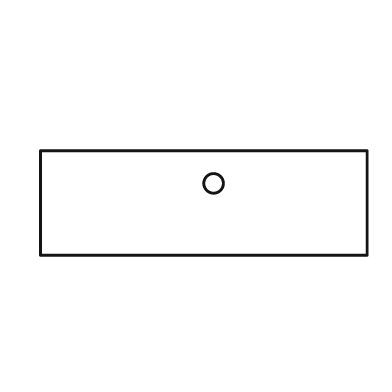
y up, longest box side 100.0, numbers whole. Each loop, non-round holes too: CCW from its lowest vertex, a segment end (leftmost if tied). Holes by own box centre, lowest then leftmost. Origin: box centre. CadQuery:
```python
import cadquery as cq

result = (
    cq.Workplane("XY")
    .moveTo(-50.0, -16.0)
    .lineTo(50.0, -16.0)
    .lineTo(50.0, 16.0)
    .lineTo(-50.0, 16.0)
    .close()
    .moveTo(3.0, 6.0)
    .circle(3.0)
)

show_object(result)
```